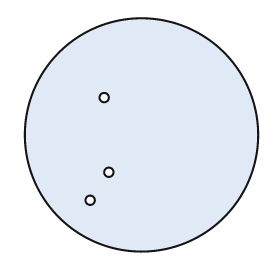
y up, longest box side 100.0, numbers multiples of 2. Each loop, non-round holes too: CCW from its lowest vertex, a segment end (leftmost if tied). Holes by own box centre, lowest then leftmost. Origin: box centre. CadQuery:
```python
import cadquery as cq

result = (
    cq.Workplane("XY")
    .moveTo(0.0, 0.0)
    .circle(50.0)
    .moveTo(-22.0, -28.0)
    .circle(2.0)
    .moveTo(-14.0, -16.0)
    .circle(2.0)
    .moveTo(-16.0, 16.0)
    .circle(2.0)
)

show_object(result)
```